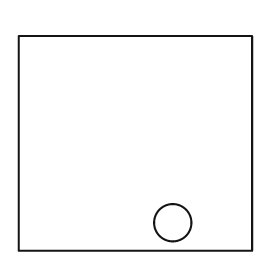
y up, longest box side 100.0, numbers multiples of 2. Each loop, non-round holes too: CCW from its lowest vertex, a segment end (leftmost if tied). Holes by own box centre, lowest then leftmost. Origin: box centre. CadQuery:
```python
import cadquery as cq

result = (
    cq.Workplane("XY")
    .moveTo(-50.0, -46.0)
    .lineTo(50.0, -46.0)
    .lineTo(50.0, 46.0)
    .lineTo(-50.0, 46.0)
    .close()
    .moveTo(16.0, -34.0)
    .circle(8.0)
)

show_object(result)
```